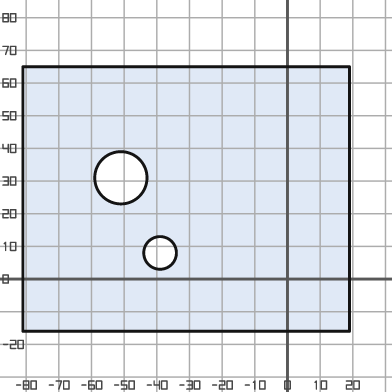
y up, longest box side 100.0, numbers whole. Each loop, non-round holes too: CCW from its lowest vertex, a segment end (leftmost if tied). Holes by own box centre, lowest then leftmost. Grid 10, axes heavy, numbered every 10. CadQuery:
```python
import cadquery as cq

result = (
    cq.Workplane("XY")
    .moveTo(-81.0, -16.0)
    .lineTo(19.0, -16.0)
    .lineTo(19.0, 65.0)
    .lineTo(-81.0, 65.0)
    .close()
    .moveTo(-39.0, 8.0)
    .circle(5.0)
    .moveTo(-51.0, 31.0)
    .circle(8.0)
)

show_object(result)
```